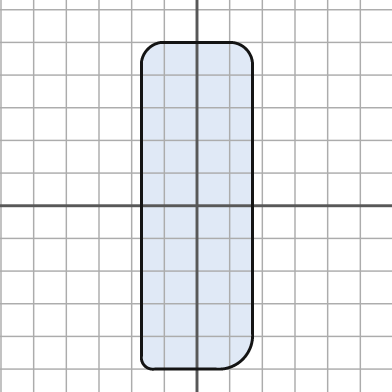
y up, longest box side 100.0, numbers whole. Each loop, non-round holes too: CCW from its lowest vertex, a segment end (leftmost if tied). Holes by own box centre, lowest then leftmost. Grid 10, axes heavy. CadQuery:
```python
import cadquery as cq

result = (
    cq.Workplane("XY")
    .moveTo(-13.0, -50.0)
    .lineTo(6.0, -50.0)
    .threePointArc((14.0, -47.0), (17.0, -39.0))
    .lineTo(17.0, 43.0)
    .threePointArc((15.0, 48.0), (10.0, 50.0))
    .lineTo(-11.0, 50.0)
    .threePointArc((-15.0, 48.0), (-17.0, 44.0))
    .lineTo(-17.0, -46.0)
    .threePointArc((-16.0, -49.0), (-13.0, -50.0))
    .close()
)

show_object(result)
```